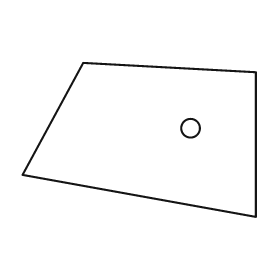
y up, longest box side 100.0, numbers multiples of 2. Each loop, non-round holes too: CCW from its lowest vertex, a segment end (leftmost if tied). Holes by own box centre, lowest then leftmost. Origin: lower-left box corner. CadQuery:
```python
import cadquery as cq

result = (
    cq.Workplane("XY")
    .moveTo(100.0, 0.0)
    .lineTo(100.0, 62.0)
    .lineTo(26.0, 66.0)
    .lineTo(0.0, 18.0)
    .close()
    .moveTo(72.0, 38.0)
    .circle(4.0)
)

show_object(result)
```